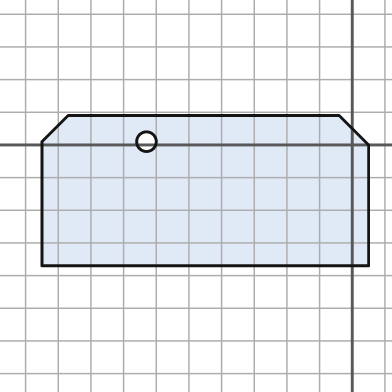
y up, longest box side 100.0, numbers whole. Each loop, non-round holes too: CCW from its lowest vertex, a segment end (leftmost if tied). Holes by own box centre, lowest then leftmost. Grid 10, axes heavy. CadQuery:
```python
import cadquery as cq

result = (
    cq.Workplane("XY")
    .moveTo(-95.0, -37.0)
    .lineTo(5.0, -37.0)
    .lineTo(5.0, 0.0)
    .lineTo(-4.0, 9.0)
    .lineTo(-87.0, 9.0)
    .lineTo(-95.0, 1.0)
    .close()
    .moveTo(-63.0, 1.0)
    .circle(3.0)
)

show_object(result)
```